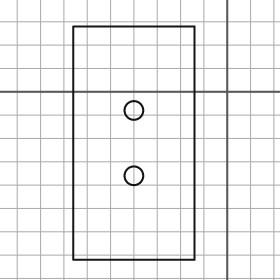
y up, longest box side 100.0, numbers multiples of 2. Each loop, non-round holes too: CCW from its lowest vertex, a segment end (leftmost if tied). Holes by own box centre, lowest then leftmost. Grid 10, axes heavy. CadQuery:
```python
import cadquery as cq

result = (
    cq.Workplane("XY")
    .moveTo(-66.0, -72.0)
    .lineTo(-14.0, -72.0)
    .lineTo(-14.0, 28.0)
    .lineTo(-66.0, 28.0)
    .close()
    .moveTo(-40.0, -36.0)
    .circle(4.0)
    .moveTo(-40.0, -8.0)
    .circle(4.0)
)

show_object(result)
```